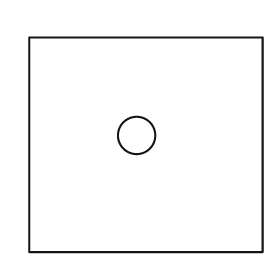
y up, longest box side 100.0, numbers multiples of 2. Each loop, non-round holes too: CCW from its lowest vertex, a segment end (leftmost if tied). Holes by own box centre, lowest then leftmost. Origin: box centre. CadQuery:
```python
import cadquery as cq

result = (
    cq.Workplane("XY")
    .moveTo(-50.0, -46.0)
    .lineTo(50.0, -46.0)
    .lineTo(50.0, 46.0)
    .lineTo(-50.0, 46.0)
    .close()
    .moveTo(-4.0, 4.0)
    .circle(8.0)
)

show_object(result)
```